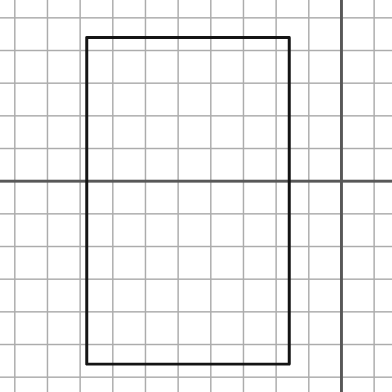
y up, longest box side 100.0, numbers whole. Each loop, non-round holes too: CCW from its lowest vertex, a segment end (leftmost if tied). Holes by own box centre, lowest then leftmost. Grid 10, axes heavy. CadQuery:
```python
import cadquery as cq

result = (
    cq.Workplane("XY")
    .moveTo(-78.0, -56.0)
    .lineTo(-16.0, -56.0)
    .lineTo(-16.0, 44.0)
    .lineTo(-78.0, 44.0)
    .close()
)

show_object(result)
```